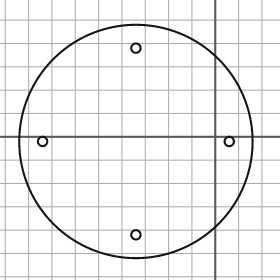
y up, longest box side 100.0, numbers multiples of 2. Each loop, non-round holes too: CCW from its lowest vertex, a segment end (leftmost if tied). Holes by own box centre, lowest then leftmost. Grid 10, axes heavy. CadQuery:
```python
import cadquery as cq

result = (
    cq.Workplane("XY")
    .moveTo(-34.0, -2.0)
    .circle(50.0)
    .moveTo(-34.0, -42.0)
    .circle(2.0)
    .moveTo(-74.0, -2.0)
    .circle(2.0)
    .moveTo(6.0, -2.0)
    .circle(2.0)
    .moveTo(-34.0, 38.0)
    .circle(2.0)
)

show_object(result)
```